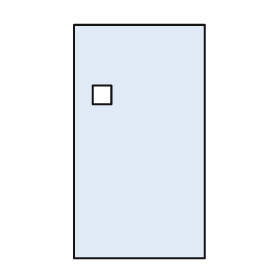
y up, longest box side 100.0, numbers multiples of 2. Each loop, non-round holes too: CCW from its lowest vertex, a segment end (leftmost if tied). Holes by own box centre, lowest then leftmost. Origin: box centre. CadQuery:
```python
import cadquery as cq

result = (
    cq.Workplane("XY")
    .moveTo(-28.0, -50.0)
    .lineTo(28.0, -50.0)
    .lineTo(28.0, 50.0)
    .lineTo(-28.0, 50.0)
    .close()
    .moveTo(-20.0, 16.0)
    .lineTo(-12.0, 16.0)
    .lineTo(-12.0, 24.0)
    .lineTo(-20.0, 24.0)
    .close()
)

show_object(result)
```